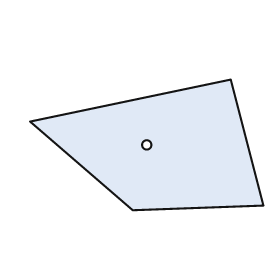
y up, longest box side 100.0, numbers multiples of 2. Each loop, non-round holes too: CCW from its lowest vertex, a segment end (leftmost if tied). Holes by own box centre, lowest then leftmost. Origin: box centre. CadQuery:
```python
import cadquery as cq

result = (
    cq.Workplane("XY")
    .moveTo(-6.0, -28.0)
    .lineTo(50.0, -26.0)
    .lineTo(36.0, 28.0)
    .lineTo(-50.0, 10.0)
    .close()
    .moveTo(0.0, 0.0)
    .circle(2.0)
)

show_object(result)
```